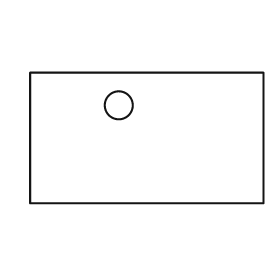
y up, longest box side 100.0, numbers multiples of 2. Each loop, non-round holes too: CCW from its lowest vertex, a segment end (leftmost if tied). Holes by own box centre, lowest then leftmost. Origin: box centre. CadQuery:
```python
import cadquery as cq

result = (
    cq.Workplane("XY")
    .moveTo(-50.0, -28.0)
    .lineTo(50.0, -28.0)
    .lineTo(50.0, 28.0)
    .lineTo(-50.0, 28.0)
    .close()
    .moveTo(-12.0, 14.0)
    .circle(6.0)
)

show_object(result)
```